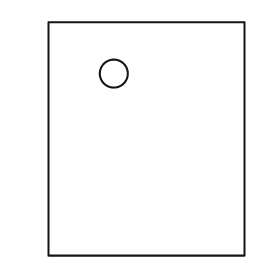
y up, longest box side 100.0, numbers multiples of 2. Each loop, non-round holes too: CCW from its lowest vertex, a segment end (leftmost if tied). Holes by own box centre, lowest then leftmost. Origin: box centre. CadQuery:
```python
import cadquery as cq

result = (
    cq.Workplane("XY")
    .moveTo(-42.0, -50.0)
    .lineTo(42.0, -50.0)
    .lineTo(42.0, 50.0)
    .lineTo(-42.0, 50.0)
    .close()
    .moveTo(-14.0, 28.0)
    .circle(6.0)
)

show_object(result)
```